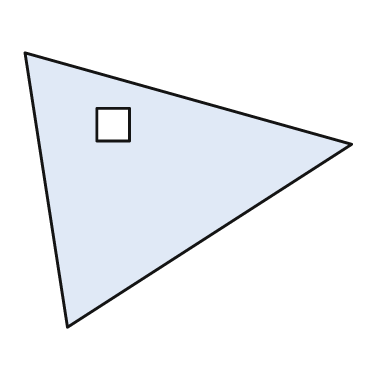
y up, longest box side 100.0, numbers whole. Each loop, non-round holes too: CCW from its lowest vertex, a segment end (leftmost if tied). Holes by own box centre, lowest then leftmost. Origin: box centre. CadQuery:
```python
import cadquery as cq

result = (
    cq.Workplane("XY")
    .moveTo(-37.0, -42.0)
    .lineTo(50.0, 14.0)
    .lineTo(-50.0, 42.0)
    .close()
    .moveTo(-28.0, 15.0)
    .lineTo(-18.0, 15.0)
    .lineTo(-18.0, 25.0)
    .lineTo(-28.0, 25.0)
    .close()
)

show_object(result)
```